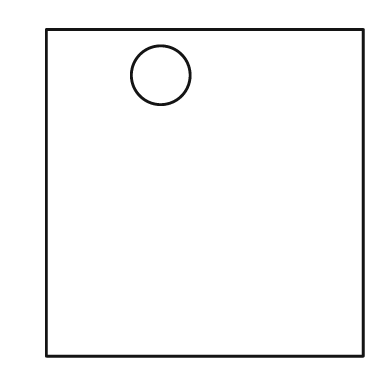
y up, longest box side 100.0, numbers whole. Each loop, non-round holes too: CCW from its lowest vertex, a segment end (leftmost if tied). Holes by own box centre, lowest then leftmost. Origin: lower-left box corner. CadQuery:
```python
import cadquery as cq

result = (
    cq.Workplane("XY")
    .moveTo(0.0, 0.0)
    .lineTo(97.0, 0.0)
    .lineTo(97.0, 100.0)
    .lineTo(0.0, 100.0)
    .close()
    .moveTo(35.0, 86.0)
    .circle(9.0)
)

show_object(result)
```